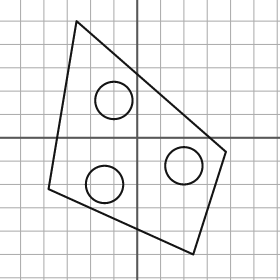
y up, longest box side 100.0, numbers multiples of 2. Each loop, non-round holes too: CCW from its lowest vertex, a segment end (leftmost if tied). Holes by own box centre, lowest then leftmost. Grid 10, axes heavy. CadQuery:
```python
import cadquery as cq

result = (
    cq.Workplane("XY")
    .moveTo(24.0, -50.0)
    .lineTo(38.0, -6.0)
    .lineTo(-26.0, 50.0)
    .lineTo(-38.0, -22.0)
    .close()
    .moveTo(-14.0, -20.0)
    .circle(8.0)
    .moveTo(20.0, -12.0)
    .circle(8.0)
    .moveTo(-10.0, 16.0)
    .circle(8.0)
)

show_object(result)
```